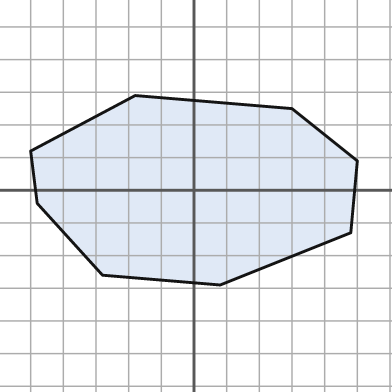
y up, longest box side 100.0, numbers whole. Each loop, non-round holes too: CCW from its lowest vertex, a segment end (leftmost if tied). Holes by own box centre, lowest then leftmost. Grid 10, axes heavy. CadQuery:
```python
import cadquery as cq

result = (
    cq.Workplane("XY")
    .moveTo(8.0, -29.0)
    .lineTo(48.0, -13.0)
    .lineTo(50.0, 9.0)
    .lineTo(30.0, 25.0)
    .lineTo(-18.0, 29.0)
    .lineTo(-50.0, 12.0)
    .lineTo(-48.0, -4.0)
    .lineTo(-28.0, -26.0)
    .close()
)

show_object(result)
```